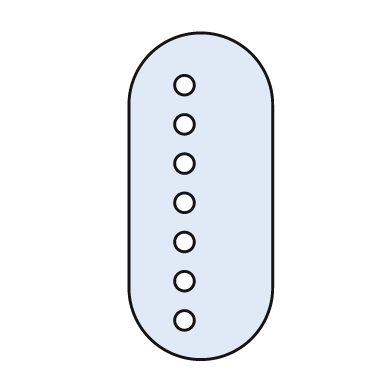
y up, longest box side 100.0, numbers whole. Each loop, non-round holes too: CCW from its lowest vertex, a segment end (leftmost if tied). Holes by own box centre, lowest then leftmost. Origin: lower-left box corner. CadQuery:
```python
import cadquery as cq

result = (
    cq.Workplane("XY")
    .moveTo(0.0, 22.0)
    .threePointArc((22.0, 0.0), (44.0, 22.0))
    .lineTo(44.0, 78.0)
    .threePointArc((22.0, 100.0), (0.0, 78.0))
    .close()
    .moveTo(17.0, 12.0)
    .circle(3.0)
    .moveTo(17.0, 24.0)
    .circle(3.0)
    .moveTo(17.0, 36.0)
    .circle(3.0)
    .moveTo(17.0, 48.0)
    .circle(3.0)
    .moveTo(17.0, 60.0)
    .circle(3.0)
    .moveTo(17.0, 72.0)
    .circle(3.0)
    .moveTo(17.0, 84.0)
    .circle(3.0)
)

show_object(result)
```